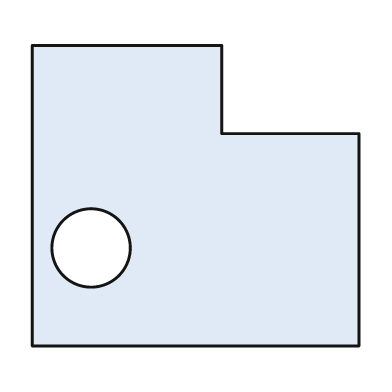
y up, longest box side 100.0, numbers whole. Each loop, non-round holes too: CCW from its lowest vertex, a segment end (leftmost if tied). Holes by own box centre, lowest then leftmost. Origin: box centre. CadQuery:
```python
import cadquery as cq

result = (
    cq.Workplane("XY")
    .moveTo(-50.0, -46.0)
    .lineTo(50.0, -46.0)
    .lineTo(50.0, 19.0)
    .lineTo(8.0, 19.0)
    .lineTo(8.0, 46.0)
    .lineTo(-50.0, 46.0)
    .close()
    .moveTo(-32.0, -16.0)
    .circle(12.0)
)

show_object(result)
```